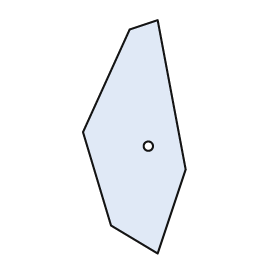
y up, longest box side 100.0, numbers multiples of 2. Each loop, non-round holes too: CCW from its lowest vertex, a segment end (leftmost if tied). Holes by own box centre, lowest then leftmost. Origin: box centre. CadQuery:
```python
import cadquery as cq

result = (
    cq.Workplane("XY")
    .moveTo(10.0, -50.0)
    .lineTo(22.0, -14.0)
    .lineTo(10.0, 50.0)
    .lineTo(-2.0, 46.0)
    .lineTo(-22.0, 2.0)
    .lineTo(-10.0, -38.0)
    .close()
    .moveTo(6.0, -4.0)
    .circle(2.0)
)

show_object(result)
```